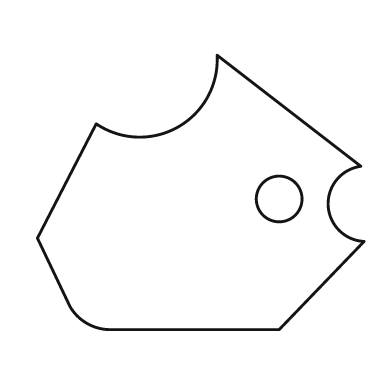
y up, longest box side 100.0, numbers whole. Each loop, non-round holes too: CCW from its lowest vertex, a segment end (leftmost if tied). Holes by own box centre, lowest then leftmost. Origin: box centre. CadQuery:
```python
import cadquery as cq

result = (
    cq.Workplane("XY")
    .moveTo(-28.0, -42.0)
    .lineTo(24.0, -42.0)
    .lineTo(50.0, -15.0)
    .threePointArc((39.0, -4.0), (49.0, 8.0))
    .lineTo(5.0, 42.0)
    .threePointArc((-7.0, 20.0), (-32.0, 21.0))
    .lineTo(-50.0, -14.0)
    .lineTo(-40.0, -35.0)
    .threePointArc((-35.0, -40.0), (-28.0, -42.0))
    .close()
    .moveTo(24.0, -2.0)
    .circle(7.0)
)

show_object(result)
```